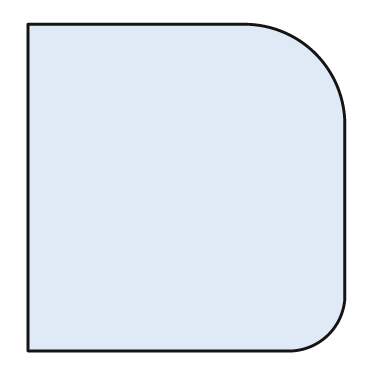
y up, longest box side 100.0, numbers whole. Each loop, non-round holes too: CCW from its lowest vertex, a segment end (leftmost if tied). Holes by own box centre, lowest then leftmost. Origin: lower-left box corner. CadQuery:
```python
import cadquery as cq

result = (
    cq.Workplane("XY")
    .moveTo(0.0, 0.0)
    .lineTo(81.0, 0.0)
    .threePointArc((92.0, 5.0), (97.0, 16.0))
    .lineTo(97.0, 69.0)
    .threePointArc((88.0, 91.0), (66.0, 100.0))
    .lineTo(0.0, 100.0)
    .close()
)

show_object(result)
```